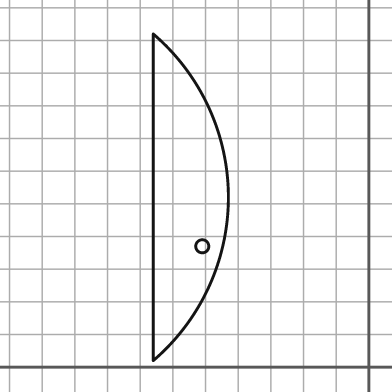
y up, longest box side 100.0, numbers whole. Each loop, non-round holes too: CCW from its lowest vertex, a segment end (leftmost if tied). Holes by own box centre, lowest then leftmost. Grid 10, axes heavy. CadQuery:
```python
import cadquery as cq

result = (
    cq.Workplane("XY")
    .moveTo(-66.0, 2.0)
    .threePointArc((-43.0, 52.0), (-66.0, 102.0))
    .close()
    .moveTo(-51.0, 37.0)
    .circle(2.0)
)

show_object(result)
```